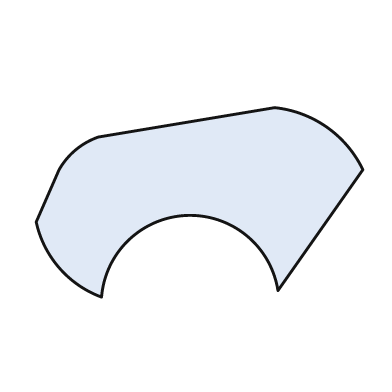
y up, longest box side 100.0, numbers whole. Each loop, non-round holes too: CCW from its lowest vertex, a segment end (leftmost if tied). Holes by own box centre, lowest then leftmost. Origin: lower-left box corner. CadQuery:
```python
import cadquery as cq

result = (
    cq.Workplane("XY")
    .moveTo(20.0, 0.0)
    .threePointArc((46.0, 25.0), (74.0, 2.0))
    .lineTo(100.0, 39.0)
    .threePointArc((89.0, 52.0), (73.0, 58.0))
    .lineTo(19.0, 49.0)
    .threePointArc((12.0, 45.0), (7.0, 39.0))
    .lineTo(0.0, 23.0)
    .threePointArc((7.0, 9.0), (20.0, 0.0))
    .close()
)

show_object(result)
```